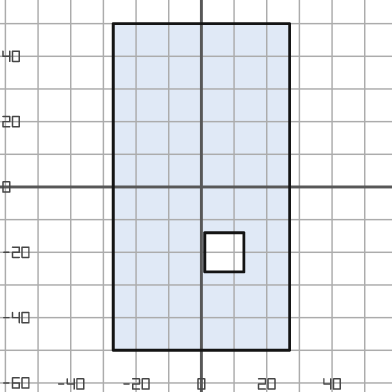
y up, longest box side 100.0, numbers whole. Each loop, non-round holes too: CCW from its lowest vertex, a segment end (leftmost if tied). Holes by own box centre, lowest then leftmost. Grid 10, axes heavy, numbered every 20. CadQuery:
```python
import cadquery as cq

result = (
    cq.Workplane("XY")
    .moveTo(-27.0, -50.0)
    .lineTo(27.0, -50.0)
    .lineTo(27.0, 50.0)
    .lineTo(-27.0, 50.0)
    .close()
    .moveTo(1.0, -26.0)
    .lineTo(13.0, -26.0)
    .lineTo(13.0, -14.0)
    .lineTo(1.0, -14.0)
    .close()
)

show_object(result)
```